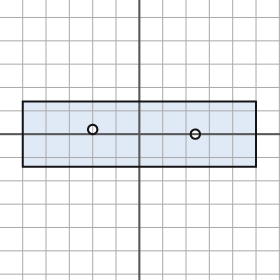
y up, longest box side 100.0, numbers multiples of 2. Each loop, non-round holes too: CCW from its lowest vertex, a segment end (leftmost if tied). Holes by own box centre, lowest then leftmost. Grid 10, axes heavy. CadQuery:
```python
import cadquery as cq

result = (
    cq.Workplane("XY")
    .moveTo(-50.0, -14.0)
    .lineTo(50.0, -14.0)
    .lineTo(50.0, 14.0)
    .lineTo(-50.0, 14.0)
    .close()
    .moveTo(24.0, 0.0)
    .circle(2.0)
    .moveTo(-20.0, 2.0)
    .circle(2.0)
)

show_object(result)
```